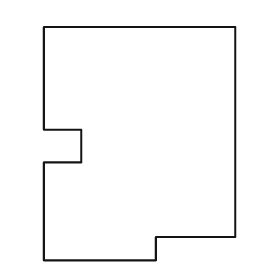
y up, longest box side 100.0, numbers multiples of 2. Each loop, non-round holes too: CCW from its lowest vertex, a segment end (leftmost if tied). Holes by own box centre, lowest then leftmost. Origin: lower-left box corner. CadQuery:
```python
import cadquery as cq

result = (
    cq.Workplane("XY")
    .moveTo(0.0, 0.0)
    .lineTo(48.0, 0.0)
    .lineTo(48.0, 10.0)
    .lineTo(82.0, 10.0)
    .lineTo(82.0, 100.0)
    .lineTo(0.0, 100.0)
    .lineTo(0.0, 56.0)
    .lineTo(16.0, 56.0)
    .lineTo(16.0, 42.0)
    .lineTo(0.0, 42.0)
    .close()
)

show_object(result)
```